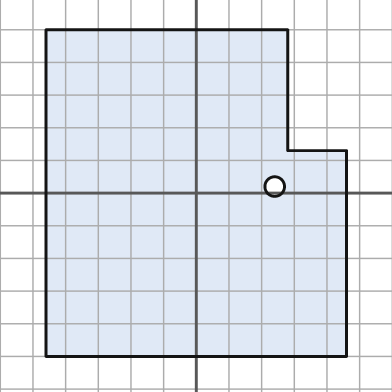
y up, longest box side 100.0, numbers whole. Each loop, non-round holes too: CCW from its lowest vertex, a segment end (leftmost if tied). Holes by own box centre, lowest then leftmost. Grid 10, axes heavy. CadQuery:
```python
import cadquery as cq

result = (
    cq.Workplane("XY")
    .moveTo(-46.0, -50.0)
    .lineTo(46.0, -50.0)
    .lineTo(46.0, 13.0)
    .lineTo(28.0, 13.0)
    .lineTo(28.0, 50.0)
    .lineTo(-46.0, 50.0)
    .close()
    .moveTo(24.0, 2.0)
    .circle(3.0)
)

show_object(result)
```